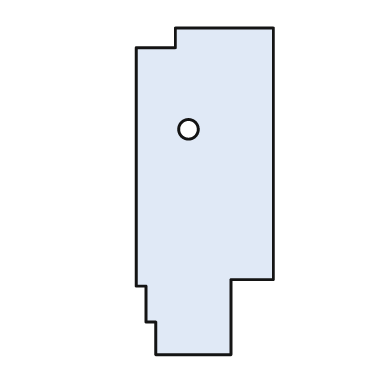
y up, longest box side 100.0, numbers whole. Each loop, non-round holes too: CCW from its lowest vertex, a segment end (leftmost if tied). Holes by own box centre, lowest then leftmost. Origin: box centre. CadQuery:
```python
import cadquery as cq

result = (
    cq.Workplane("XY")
    .moveTo(-15.0, -50.0)
    .lineTo(8.0, -50.0)
    .lineTo(8.0, -27.0)
    .lineTo(21.0, -27.0)
    .lineTo(21.0, 50.0)
    .lineTo(-9.0, 50.0)
    .lineTo(-9.0, 44.0)
    .lineTo(-21.0, 44.0)
    .lineTo(-21.0, -29.0)
    .lineTo(-18.0, -29.0)
    .lineTo(-18.0, -40.0)
    .lineTo(-15.0, -40.0)
    .close()
    .moveTo(-5.0, 19.0)
    .circle(3.0)
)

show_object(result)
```